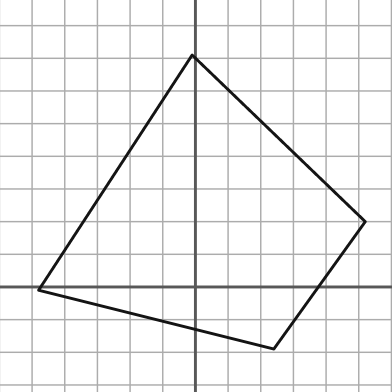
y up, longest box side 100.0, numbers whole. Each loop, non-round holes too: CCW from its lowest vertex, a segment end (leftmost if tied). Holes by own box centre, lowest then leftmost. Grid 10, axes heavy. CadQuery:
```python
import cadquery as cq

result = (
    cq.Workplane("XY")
    .moveTo(24.0, -19.0)
    .lineTo(52.0, 20.0)
    .lineTo(-1.0, 71.0)
    .lineTo(-48.0, -1.0)
    .close()
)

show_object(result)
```